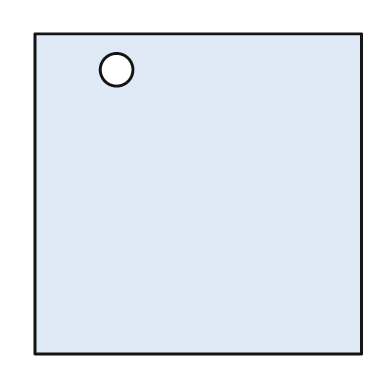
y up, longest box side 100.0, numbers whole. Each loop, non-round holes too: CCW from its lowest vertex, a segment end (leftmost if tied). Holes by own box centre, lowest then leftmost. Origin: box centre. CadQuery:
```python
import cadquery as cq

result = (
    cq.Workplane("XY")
    .moveTo(-50.0, -49.0)
    .lineTo(50.0, -49.0)
    .lineTo(50.0, 49.0)
    .lineTo(-50.0, 49.0)
    .close()
    .moveTo(-25.0, 38.0)
    .circle(5.0)
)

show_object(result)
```